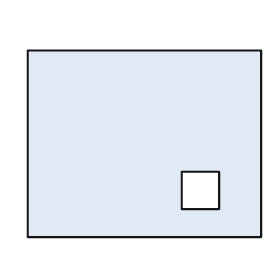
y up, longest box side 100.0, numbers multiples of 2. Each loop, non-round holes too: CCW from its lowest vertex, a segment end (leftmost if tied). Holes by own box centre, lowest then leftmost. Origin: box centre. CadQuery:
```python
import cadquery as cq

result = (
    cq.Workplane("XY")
    .moveTo(-50.0, -40.0)
    .lineTo(50.0, -40.0)
    .lineTo(50.0, 40.0)
    .lineTo(-50.0, 40.0)
    .close()
    .moveTo(16.0, -28.0)
    .lineTo(32.0, -28.0)
    .lineTo(32.0, -12.0)
    .lineTo(16.0, -12.0)
    .close()
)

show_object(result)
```